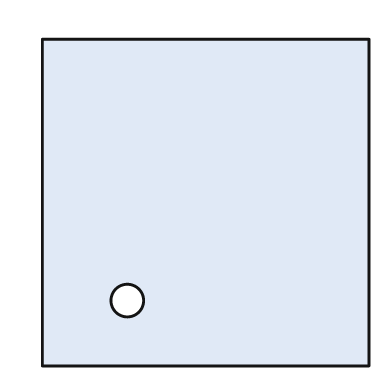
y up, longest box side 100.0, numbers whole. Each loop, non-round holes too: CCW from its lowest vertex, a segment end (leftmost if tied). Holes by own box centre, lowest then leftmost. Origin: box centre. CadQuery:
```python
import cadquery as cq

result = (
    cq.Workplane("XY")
    .moveTo(-50.0, -50.0)
    .lineTo(50.0, -50.0)
    .lineTo(50.0, 50.0)
    .lineTo(-50.0, 50.0)
    .close()
    .moveTo(-24.0, -30.0)
    .circle(5.0)
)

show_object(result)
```